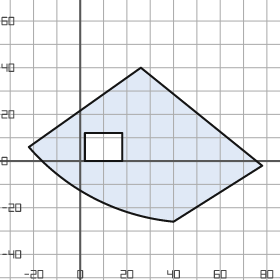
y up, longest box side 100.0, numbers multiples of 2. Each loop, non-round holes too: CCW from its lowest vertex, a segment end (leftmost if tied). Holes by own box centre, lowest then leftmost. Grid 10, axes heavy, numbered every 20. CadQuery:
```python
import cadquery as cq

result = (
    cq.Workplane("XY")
    .moveTo(40.0, -26.0)
    .lineTo(78.0, -2.0)
    .lineTo(26.0, 40.0)
    .lineTo(-22.0, 6.0)
    .threePointArc((6.0, -16.0), (40.0, -26.0))
    .close()
    .moveTo(2.0, 0.0)
    .lineTo(18.0, 0.0)
    .lineTo(18.0, 12.0)
    .lineTo(2.0, 12.0)
    .close()
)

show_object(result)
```